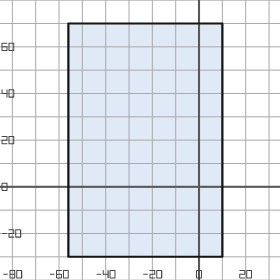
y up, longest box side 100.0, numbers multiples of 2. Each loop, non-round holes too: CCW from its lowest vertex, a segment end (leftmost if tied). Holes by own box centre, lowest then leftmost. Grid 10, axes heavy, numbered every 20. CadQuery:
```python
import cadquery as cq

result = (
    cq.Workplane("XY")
    .moveTo(-56.0, -30.0)
    .lineTo(10.0, -30.0)
    .lineTo(10.0, 70.0)
    .lineTo(-56.0, 70.0)
    .close()
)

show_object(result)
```